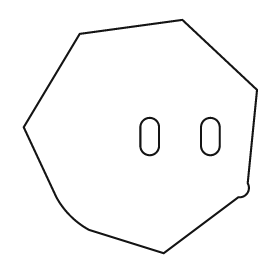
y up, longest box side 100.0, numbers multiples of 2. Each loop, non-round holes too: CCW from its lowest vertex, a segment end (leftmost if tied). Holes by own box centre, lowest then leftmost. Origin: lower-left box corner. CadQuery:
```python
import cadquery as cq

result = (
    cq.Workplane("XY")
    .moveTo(60.0, 0.0)
    .lineTo(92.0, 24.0)
    .threePointArc((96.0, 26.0), (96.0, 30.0))
    .lineTo(100.0, 70.0)
    .lineTo(68.0, 100.0)
    .lineTo(24.0, 94.0)
    .lineTo(0.0, 54.0)
    .lineTo(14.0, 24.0)
    .threePointArc((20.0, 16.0), (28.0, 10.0))
    .close()
    .moveTo(50.0, 46.0)
    .threePointArc((54.0, 42.0), (58.0, 46.0))
    .lineTo(58.0, 54.0)
    .threePointArc((54.0, 58.0), (50.0, 54.0))
    .close()
    .moveTo(76.0, 46.0)
    .threePointArc((80.0, 42.0), (84.0, 46.0))
    .lineTo(84.0, 54.0)
    .threePointArc((80.0, 58.0), (76.0, 54.0))
    .close()
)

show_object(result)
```